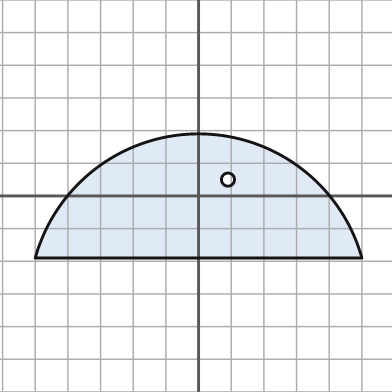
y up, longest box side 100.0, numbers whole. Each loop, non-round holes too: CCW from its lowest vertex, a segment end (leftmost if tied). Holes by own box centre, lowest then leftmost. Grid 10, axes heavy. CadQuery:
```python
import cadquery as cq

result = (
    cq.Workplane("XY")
    .moveTo(-50.0, -19.0)
    .lineTo(50.0, -19.0)
    .threePointArc((0.0, 19.0), (-50.0, -19.0))
    .close()
    .moveTo(9.0, 5.0)
    .circle(2.0)
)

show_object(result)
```